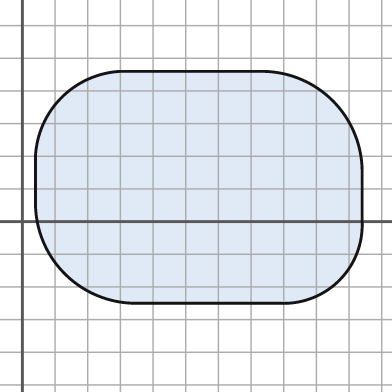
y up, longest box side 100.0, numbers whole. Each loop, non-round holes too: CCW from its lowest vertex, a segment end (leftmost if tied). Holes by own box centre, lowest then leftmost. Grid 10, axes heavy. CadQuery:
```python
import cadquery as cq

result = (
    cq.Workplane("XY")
    .moveTo(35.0, -25.0)
    .lineTo(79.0, -25.0)
    .threePointArc((97.0, -18.0), (104.0, 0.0))
    .lineTo(104.0, 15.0)
    .threePointArc((95.0, 37.0), (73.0, 46.0))
    .lineTo(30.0, 46.0)
    .threePointArc((12.0, 38.0), (4.0, 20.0))
    .lineTo(4.0, 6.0)
    .threePointArc((13.0, -16.0), (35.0, -25.0))
    .close()
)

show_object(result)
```